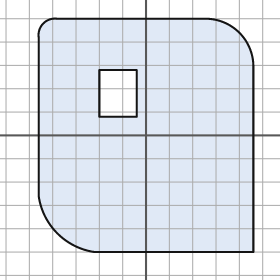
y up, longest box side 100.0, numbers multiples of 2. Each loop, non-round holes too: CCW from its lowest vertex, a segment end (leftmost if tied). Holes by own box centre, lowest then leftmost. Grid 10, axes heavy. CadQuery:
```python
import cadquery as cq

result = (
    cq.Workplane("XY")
    .moveTo(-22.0, -50.0)
    .lineTo(46.0, -50.0)
    .lineTo(46.0, 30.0)
    .threePointArc((40.0, 44.0), (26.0, 50.0))
    .lineTo(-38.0, 50.0)
    .threePointArc((-44.0, 48.0), (-46.0, 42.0))
    .lineTo(-46.0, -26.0)
    .threePointArc((-38.0, -42.0), (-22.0, -50.0))
    .close()
    .moveTo(-20.0, 8.0)
    .lineTo(-4.0, 8.0)
    .lineTo(-4.0, 28.0)
    .lineTo(-20.0, 28.0)
    .close()
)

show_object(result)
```